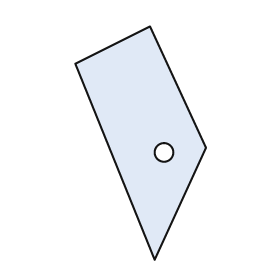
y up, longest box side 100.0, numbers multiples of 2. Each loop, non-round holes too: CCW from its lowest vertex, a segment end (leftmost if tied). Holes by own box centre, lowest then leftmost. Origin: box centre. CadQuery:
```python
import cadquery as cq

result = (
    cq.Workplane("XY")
    .moveTo(6.0, -50.0)
    .lineTo(28.0, -2.0)
    .lineTo(4.0, 50.0)
    .lineTo(-28.0, 34.0)
    .close()
    .moveTo(10.0, -4.0)
    .circle(4.0)
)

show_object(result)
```